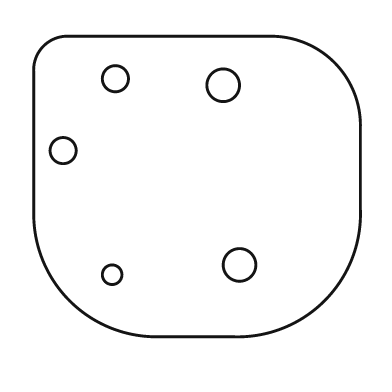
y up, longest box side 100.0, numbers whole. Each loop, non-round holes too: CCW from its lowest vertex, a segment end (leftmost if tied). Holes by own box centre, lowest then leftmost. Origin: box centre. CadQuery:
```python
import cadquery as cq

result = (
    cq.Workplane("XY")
    .moveTo(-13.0, -46.0)
    .lineTo(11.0, -46.0)
    .threePointArc((39.0, -35.0), (50.0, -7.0))
    .lineTo(50.0, 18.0)
    .threePointArc((42.0, 38.0), (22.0, 46.0))
    .lineTo(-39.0, 46.0)
    .threePointArc((-47.0, 43.0), (-50.0, 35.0))
    .lineTo(-50.0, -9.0)
    .threePointArc((-39.0, -35.0), (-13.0, -46.0))
    .close()
    .moveTo(-26.0, -27.0)
    .circle(3.0)
    .moveTo(13.0, -24.0)
    .circle(5.0)
    .moveTo(-41.0, 11.0)
    .circle(4.0)
    .moveTo(8.0, 31.0)
    .circle(5.0)
    .moveTo(-25.0, 33.0)
    .circle(4.0)
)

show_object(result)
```